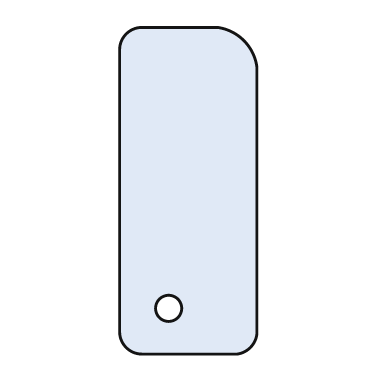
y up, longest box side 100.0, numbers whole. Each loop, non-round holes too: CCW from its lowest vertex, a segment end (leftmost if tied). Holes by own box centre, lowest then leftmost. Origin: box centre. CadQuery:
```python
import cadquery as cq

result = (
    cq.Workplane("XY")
    .moveTo(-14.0, -50.0)
    .lineTo(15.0, -50.0)
    .threePointArc((19.0, -48.0), (21.0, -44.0))
    .lineTo(21.0, 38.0)
    .threePointArc((17.0, 46.0), (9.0, 50.0))
    .lineTo(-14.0, 50.0)
    .threePointArc((-19.0, 48.0), (-21.0, 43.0))
    .lineTo(-21.0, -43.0)
    .threePointArc((-19.0, -48.0), (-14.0, -50.0))
    .close()
    .moveTo(-6.0, -36.0)
    .circle(4.0)
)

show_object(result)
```